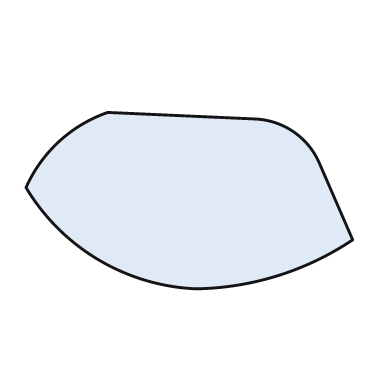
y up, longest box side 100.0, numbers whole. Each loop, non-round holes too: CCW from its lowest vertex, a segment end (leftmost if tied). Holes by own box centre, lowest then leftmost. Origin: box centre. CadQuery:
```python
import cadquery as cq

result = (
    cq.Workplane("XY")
    .moveTo(2.0, -27.0)
    .threePointArc((27.0, -23.0), (50.0, -12.0))
    .lineTo(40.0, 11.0)
    .threePointArc((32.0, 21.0), (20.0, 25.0))
    .lineTo(-25.0, 27.0)
    .threePointArc((-40.0, 18.0), (-50.0, 4.0))
    .threePointArc((-28.0, -18.0), (2.0, -27.0))
    .close()
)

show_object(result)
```